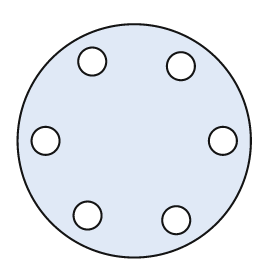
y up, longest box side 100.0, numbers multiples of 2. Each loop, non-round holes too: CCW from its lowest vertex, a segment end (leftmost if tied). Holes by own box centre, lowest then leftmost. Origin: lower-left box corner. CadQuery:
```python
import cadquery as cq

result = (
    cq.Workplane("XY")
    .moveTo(50.0, 50.0)
    .circle(50.0)
    .moveTo(68.0, 16.0)
    .circle(6.0)
    .moveTo(30.0, 18.0)
    .circle(6.0)
    .moveTo(12.0, 50.0)
    .circle(6.0)
    .moveTo(88.0, 50.0)
    .circle(6.0)
    .moveTo(70.0, 82.0)
    .circle(6.0)
    .moveTo(32.0, 84.0)
    .circle(6.0)
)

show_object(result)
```